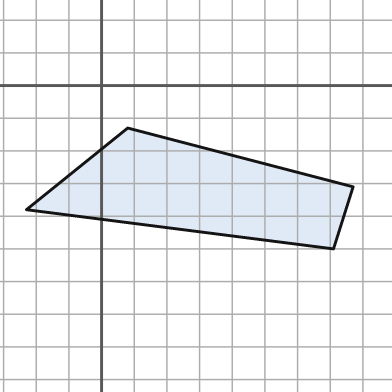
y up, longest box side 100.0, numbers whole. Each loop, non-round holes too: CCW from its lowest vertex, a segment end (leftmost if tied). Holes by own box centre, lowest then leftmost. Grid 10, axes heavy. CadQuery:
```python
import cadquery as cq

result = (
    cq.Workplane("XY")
    .moveTo(71.0, -50.0)
    .lineTo(77.0, -31.0)
    .lineTo(8.0, -13.0)
    .lineTo(-23.0, -38.0)
    .close()
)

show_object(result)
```